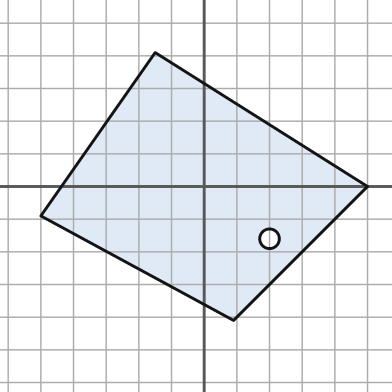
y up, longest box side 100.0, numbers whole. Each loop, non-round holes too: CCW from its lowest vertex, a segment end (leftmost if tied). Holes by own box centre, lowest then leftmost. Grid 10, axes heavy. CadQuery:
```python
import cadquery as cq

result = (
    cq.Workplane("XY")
    .moveTo(9.0, -41.0)
    .lineTo(50.0, 0.0)
    .lineTo(-15.0, 41.0)
    .lineTo(-50.0, -9.0)
    .close()
    .moveTo(20.0, -16.0)
    .circle(3.0)
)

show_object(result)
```